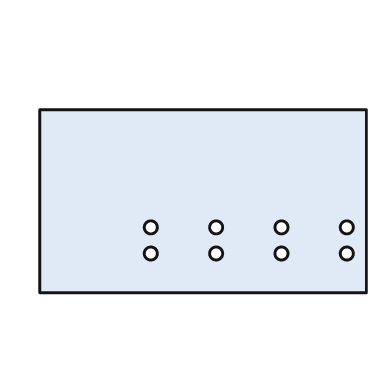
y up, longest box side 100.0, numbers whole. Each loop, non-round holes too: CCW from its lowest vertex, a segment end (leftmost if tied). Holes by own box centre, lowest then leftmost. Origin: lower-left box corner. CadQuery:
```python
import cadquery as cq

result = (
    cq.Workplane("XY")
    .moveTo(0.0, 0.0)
    .lineTo(100.0, 0.0)
    .lineTo(100.0, 56.0)
    .lineTo(0.0, 56.0)
    .close()
    .moveTo(34.0, 12.0)
    .circle(2.0)
    .moveTo(54.0, 12.0)
    .circle(2.0)
    .moveTo(74.0, 12.0)
    .circle(2.0)
    .moveTo(94.0, 12.0)
    .circle(2.0)
    .moveTo(34.0, 20.0)
    .circle(2.0)
    .moveTo(54.0, 20.0)
    .circle(2.0)
    .moveTo(74.0, 20.0)
    .circle(2.0)
    .moveTo(94.0, 20.0)
    .circle(2.0)
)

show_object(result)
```